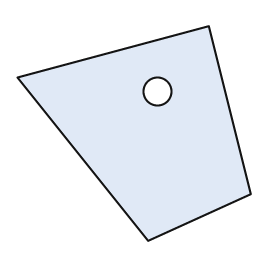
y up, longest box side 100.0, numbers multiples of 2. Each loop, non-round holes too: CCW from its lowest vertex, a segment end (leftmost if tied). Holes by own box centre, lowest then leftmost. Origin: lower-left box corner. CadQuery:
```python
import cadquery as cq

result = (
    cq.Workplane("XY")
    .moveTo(56.0, 0.0)
    .lineTo(100.0, 20.0)
    .lineTo(82.0, 92.0)
    .lineTo(0.0, 70.0)
    .close()
    .moveTo(60.0, 64.0)
    .circle(6.0)
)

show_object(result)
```